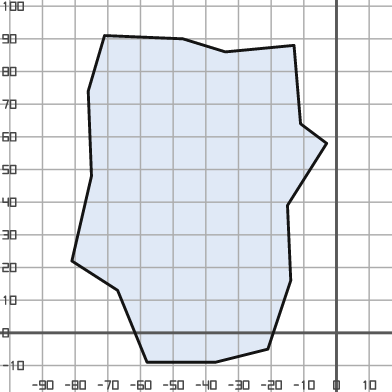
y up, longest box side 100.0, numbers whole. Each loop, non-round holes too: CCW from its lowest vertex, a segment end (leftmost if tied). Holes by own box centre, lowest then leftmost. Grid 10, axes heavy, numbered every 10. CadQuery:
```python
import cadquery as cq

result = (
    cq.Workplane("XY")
    .moveTo(-58.0, -9.0)
    .lineTo(-37.0, -9.0)
    .lineTo(-21.0, -5.0)
    .lineTo(-14.0, 16.0)
    .lineTo(-15.0, 39.0)
    .lineTo(-3.0, 58.0)
    .lineTo(-11.0, 64.0)
    .lineTo(-13.0, 88.0)
    .lineTo(-34.0, 86.0)
    .lineTo(-47.0, 90.0)
    .lineTo(-71.0, 91.0)
    .lineTo(-76.0, 74.0)
    .lineTo(-75.0, 48.0)
    .lineTo(-81.0, 22.0)
    .lineTo(-67.0, 13.0)
    .close()
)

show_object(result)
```